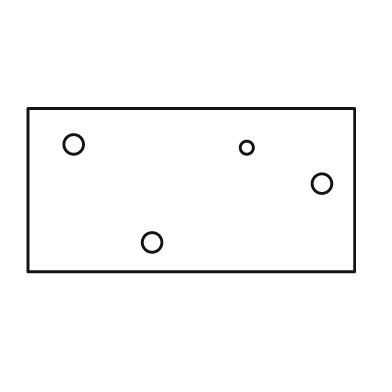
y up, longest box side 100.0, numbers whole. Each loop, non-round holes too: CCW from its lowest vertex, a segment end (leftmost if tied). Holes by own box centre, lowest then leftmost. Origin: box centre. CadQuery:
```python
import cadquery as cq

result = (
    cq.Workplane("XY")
    .moveTo(-50.0, -25.0)
    .lineTo(50.0, -25.0)
    .lineTo(50.0, 25.0)
    .lineTo(-50.0, 25.0)
    .close()
    .moveTo(-12.0, -16.0)
    .circle(3.0)
    .moveTo(40.0, 2.0)
    .circle(3.0)
    .moveTo(17.0, 13.0)
    .circle(2.0)
    .moveTo(-36.0, 14.0)
    .circle(3.0)
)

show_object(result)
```